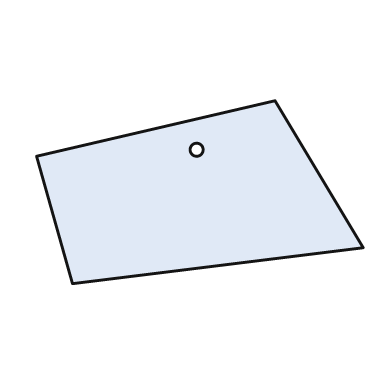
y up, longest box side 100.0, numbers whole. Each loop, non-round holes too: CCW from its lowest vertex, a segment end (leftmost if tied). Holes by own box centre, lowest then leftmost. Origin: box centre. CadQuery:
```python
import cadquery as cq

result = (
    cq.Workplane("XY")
    .moveTo(-39.0, -28.0)
    .lineTo(50.0, -17.0)
    .lineTo(23.0, 28.0)
    .lineTo(-50.0, 11.0)
    .close()
    .moveTo(-1.0, 13.0)
    .circle(2.0)
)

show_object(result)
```